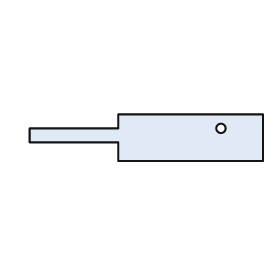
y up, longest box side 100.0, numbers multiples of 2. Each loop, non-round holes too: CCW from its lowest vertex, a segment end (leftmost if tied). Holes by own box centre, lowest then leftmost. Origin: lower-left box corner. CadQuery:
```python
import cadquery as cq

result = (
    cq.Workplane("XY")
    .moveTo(38.0, 0.0)
    .lineTo(100.0, 0.0)
    .lineTo(100.0, 20.0)
    .lineTo(38.0, 20.0)
    .lineTo(38.0, 14.0)
    .lineTo(0.0, 14.0)
    .lineTo(0.0, 8.0)
    .lineTo(38.0, 8.0)
    .close()
    .moveTo(82.0, 14.0)
    .circle(2.0)
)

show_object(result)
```